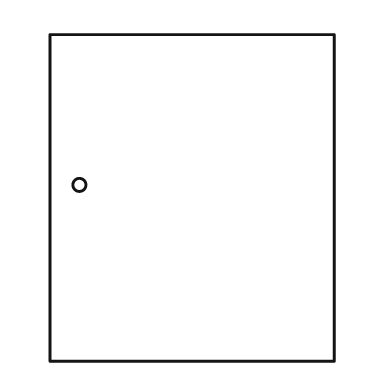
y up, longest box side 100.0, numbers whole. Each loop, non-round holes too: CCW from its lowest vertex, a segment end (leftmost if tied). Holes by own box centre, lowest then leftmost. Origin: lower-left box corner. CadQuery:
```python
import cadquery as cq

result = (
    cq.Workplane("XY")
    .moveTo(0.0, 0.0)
    .lineTo(87.0, 0.0)
    .lineTo(87.0, 100.0)
    .lineTo(0.0, 100.0)
    .close()
    .moveTo(9.0, 54.0)
    .circle(2.0)
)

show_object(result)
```